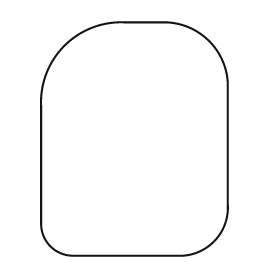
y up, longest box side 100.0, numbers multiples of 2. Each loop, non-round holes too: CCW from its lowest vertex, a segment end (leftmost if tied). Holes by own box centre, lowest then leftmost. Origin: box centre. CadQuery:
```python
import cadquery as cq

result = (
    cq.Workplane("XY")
    .moveTo(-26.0, -50.0)
    .lineTo(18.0, -50.0)
    .threePointArc((34.0, -44.0), (40.0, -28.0))
    .lineTo(40.0, 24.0)
    .threePointArc((32.0, 42.0), (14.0, 50.0))
    .lineTo(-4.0, 50.0)
    .threePointArc((-30.0, 40.0), (-40.0, 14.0))
    .lineTo(-40.0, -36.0)
    .threePointArc((-36.0, -46.0), (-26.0, -50.0))
    .close()
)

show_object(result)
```